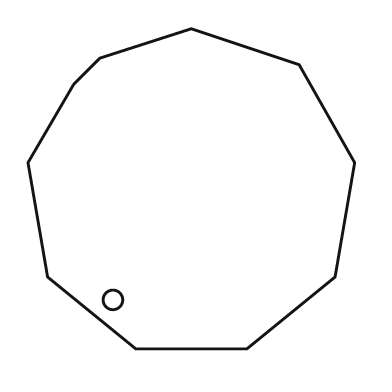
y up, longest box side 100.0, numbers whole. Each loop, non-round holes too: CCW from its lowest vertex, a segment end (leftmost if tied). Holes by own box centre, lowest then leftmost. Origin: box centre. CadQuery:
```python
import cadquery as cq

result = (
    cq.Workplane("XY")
    .moveTo(-17.0, -49.0)
    .lineTo(17.0, -49.0)
    .lineTo(44.0, -27.0)
    .lineTo(50.0, 8.0)
    .lineTo(33.0, 38.0)
    .lineTo(0.0, 49.0)
    .lineTo(-28.0, 40.0)
    .lineTo(-36.0, 32.0)
    .lineTo(-50.0, 8.0)
    .lineTo(-44.0, -27.0)
    .close()
    .moveTo(-24.0, -34.0)
    .circle(3.0)
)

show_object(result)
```